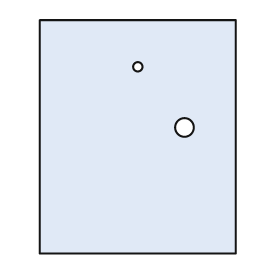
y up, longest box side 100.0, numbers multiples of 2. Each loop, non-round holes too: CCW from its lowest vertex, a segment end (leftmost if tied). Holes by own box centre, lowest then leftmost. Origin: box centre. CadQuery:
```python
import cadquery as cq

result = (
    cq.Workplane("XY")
    .moveTo(-42.0, -50.0)
    .lineTo(42.0, -50.0)
    .lineTo(42.0, 50.0)
    .lineTo(-42.0, 50.0)
    .close()
    .moveTo(20.0, 4.0)
    .circle(4.0)
    .moveTo(0.0, 30.0)
    .circle(2.0)
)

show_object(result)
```